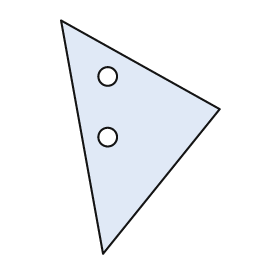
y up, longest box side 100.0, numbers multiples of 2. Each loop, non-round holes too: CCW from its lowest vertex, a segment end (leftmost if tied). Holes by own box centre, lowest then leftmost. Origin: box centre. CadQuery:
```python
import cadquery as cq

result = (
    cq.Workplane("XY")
    .moveTo(-16.0, -50.0)
    .lineTo(34.0, 12.0)
    .lineTo(-34.0, 50.0)
    .close()
    .moveTo(-14.0, 0.0)
    .circle(4.0)
    .moveTo(-14.0, 26.0)
    .circle(4.0)
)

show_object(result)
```